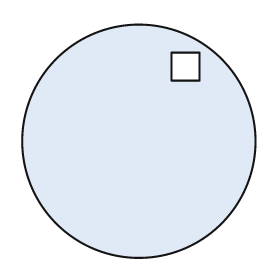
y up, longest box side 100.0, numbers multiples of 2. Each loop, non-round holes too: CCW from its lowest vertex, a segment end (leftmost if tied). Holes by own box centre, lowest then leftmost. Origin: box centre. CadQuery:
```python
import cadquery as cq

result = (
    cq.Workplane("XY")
    .moveTo(0.0, 0.0)
    .circle(50.0)
    .moveTo(14.0, 26.0)
    .lineTo(26.0, 26.0)
    .lineTo(26.0, 38.0)
    .lineTo(14.0, 38.0)
    .close()
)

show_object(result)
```